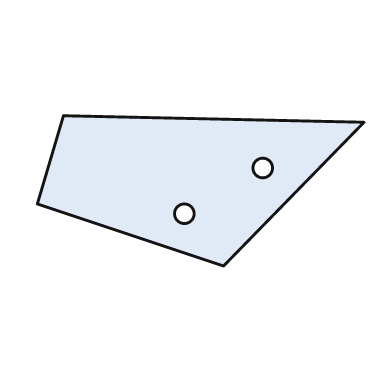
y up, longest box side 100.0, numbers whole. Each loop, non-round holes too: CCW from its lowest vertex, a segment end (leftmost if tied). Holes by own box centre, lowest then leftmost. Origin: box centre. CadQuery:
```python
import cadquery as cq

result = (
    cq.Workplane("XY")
    .moveTo(7.0, -23.0)
    .lineTo(50.0, 21.0)
    .lineTo(-42.0, 23.0)
    .lineTo(-50.0, -4.0)
    .close()
    .moveTo(-5.0, -7.0)
    .circle(3.0)
    .moveTo(19.0, 7.0)
    .circle(3.0)
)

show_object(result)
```